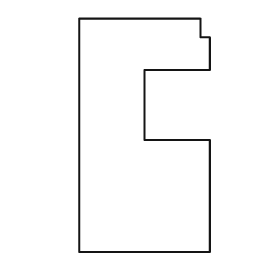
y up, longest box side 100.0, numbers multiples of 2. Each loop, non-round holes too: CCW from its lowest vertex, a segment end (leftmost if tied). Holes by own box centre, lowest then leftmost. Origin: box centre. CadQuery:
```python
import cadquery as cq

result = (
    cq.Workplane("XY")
    .moveTo(-28.0, -50.0)
    .lineTo(28.0, -50.0)
    .lineTo(28.0, -2.0)
    .lineTo(0.0, -2.0)
    .lineTo(0.0, 28.0)
    .lineTo(28.0, 28.0)
    .lineTo(28.0, 42.0)
    .lineTo(24.0, 42.0)
    .lineTo(24.0, 50.0)
    .lineTo(-28.0, 50.0)
    .close()
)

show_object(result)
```